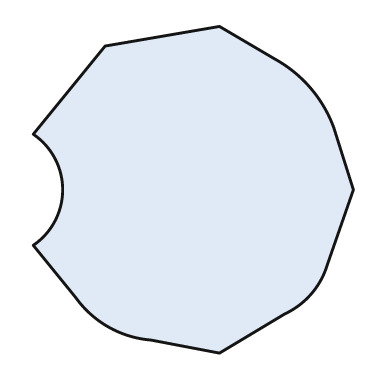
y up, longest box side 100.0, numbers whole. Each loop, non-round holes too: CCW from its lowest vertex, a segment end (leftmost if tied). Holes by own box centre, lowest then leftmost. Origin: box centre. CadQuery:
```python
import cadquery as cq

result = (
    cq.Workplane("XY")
    .moveTo(8.0, -50.0)
    .lineTo(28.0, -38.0)
    .threePointArc((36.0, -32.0), (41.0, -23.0))
    .lineTo(49.0, 0.0)
    .lineTo(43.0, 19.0)
    .threePointArc((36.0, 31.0), (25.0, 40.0))
    .lineTo(8.0, 50.0)
    .lineTo(-27.0, 44.0)
    .lineTo(-49.0, 17.0)
    .threePointArc((-40.0, 0.0), (-49.0, -17.0))
    .lineTo(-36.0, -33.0)
    .threePointArc((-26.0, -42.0), (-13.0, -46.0))
    .close()
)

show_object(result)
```